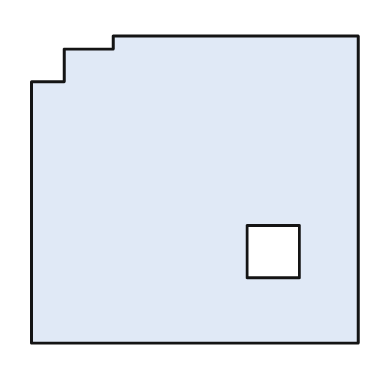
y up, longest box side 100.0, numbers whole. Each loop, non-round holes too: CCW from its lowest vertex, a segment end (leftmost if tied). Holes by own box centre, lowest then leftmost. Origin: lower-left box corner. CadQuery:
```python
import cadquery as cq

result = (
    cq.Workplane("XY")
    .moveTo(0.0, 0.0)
    .lineTo(100.0, 0.0)
    .lineTo(100.0, 94.0)
    .lineTo(25.0, 94.0)
    .lineTo(25.0, 90.0)
    .lineTo(10.0, 90.0)
    .lineTo(10.0, 80.0)
    .lineTo(0.0, 80.0)
    .close()
    .moveTo(66.0, 20.0)
    .lineTo(82.0, 20.0)
    .lineTo(82.0, 36.0)
    .lineTo(66.0, 36.0)
    .close()
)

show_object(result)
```